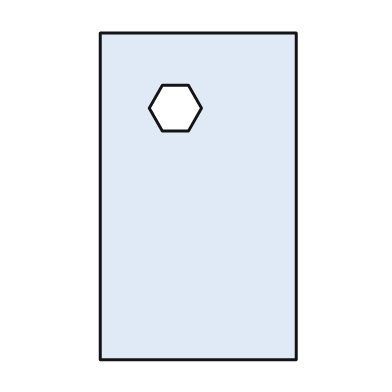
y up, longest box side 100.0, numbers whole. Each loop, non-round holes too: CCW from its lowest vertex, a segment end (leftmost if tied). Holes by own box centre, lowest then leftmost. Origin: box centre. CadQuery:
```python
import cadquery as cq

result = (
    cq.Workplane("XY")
    .moveTo(-30.0, -50.0)
    .lineTo(30.0, -50.0)
    .lineTo(30.0, 50.0)
    .lineTo(-30.0, 50.0)
    .close()
    .moveTo(-11.0, 20.0)
    .lineTo(-3.0, 20.0)
    .lineTo(1.0, 27.0)
    .lineTo(-3.0, 34.0)
    .lineTo(-11.0, 34.0)
    .lineTo(-15.0, 27.0)
    .close()
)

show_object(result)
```